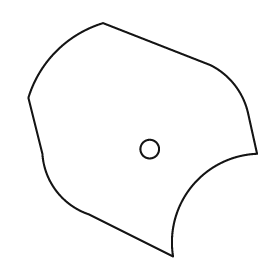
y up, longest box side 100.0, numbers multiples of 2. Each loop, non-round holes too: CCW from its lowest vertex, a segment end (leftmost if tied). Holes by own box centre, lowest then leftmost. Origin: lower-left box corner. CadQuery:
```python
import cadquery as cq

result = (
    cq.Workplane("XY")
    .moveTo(62.0, 0.0)
    .threePointArc((70.0, 30.0), (98.0, 44.0))
    .lineTo(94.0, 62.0)
    .threePointArc((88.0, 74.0), (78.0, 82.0))
    .lineTo(32.0, 100.0)
    .threePointArc((12.0, 88.0), (0.0, 68.0))
    .lineTo(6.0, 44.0)
    .threePointArc((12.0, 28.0), (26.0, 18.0))
    .close()
    .moveTo(52.0, 46.0)
    .circle(4.0)
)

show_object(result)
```